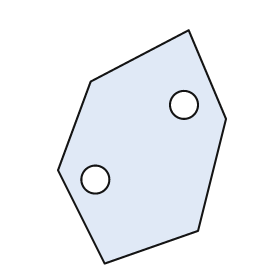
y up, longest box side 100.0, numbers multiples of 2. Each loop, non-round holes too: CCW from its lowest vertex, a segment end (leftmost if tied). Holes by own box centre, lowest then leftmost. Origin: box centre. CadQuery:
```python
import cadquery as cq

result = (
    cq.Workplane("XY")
    .moveTo(-16.0, -50.0)
    .lineTo(24.0, -36.0)
    .lineTo(36.0, 12.0)
    .lineTo(20.0, 50.0)
    .lineTo(-22.0, 28.0)
    .lineTo(-36.0, -10.0)
    .close()
    .moveTo(-20.0, -14.0)
    .circle(6.0)
    .moveTo(18.0, 18.0)
    .circle(6.0)
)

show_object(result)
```